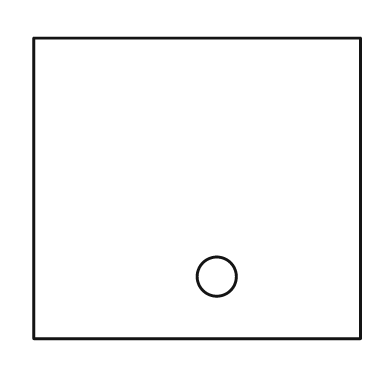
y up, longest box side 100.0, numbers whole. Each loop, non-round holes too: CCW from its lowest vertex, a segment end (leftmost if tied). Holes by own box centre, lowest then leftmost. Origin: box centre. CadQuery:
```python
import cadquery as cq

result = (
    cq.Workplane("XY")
    .moveTo(-50.0, -46.0)
    .lineTo(50.0, -46.0)
    .lineTo(50.0, 46.0)
    .lineTo(-50.0, 46.0)
    .close()
    .moveTo(6.0, -27.0)
    .circle(6.0)
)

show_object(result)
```